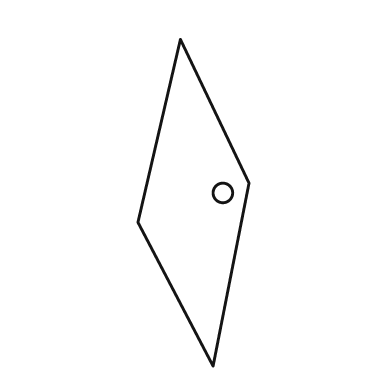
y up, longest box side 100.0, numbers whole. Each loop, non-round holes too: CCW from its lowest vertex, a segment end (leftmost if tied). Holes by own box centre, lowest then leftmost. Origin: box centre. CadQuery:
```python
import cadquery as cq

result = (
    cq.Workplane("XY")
    .moveTo(6.0, -50.0)
    .lineTo(17.0, 6.0)
    .lineTo(-4.0, 50.0)
    .lineTo(-17.0, -6.0)
    .close()
    .moveTo(9.0, 3.0)
    .circle(3.0)
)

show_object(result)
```